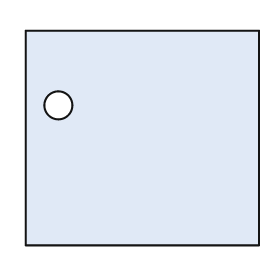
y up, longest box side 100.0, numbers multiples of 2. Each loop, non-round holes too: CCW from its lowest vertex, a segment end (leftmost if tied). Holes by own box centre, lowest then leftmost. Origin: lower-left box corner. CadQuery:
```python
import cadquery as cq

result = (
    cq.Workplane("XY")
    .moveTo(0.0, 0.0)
    .lineTo(100.0, 0.0)
    .lineTo(100.0, 92.0)
    .lineTo(0.0, 92.0)
    .close()
    .moveTo(14.0, 60.0)
    .circle(6.0)
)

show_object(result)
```